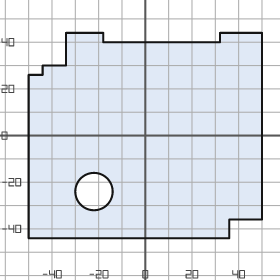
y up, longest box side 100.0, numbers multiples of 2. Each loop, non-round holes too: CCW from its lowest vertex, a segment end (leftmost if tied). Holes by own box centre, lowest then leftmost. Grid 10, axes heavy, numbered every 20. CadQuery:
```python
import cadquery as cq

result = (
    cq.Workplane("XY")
    .moveTo(-50.0, -44.0)
    .lineTo(36.0, -44.0)
    .lineTo(36.0, -36.0)
    .lineTo(50.0, -36.0)
    .lineTo(50.0, 44.0)
    .lineTo(32.0, 44.0)
    .lineTo(32.0, 40.0)
    .lineTo(-18.0, 40.0)
    .lineTo(-18.0, 44.0)
    .lineTo(-34.0, 44.0)
    .lineTo(-34.0, 30.0)
    .lineTo(-44.0, 30.0)
    .lineTo(-44.0, 26.0)
    .lineTo(-50.0, 26.0)
    .close()
    .moveTo(-22.0, -24.0)
    .circle(8.0)
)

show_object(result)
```